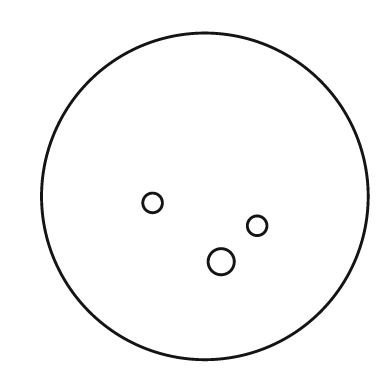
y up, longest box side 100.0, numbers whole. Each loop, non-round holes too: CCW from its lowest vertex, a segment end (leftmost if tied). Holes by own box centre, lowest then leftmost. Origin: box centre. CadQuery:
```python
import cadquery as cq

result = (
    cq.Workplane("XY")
    .moveTo(0.0, 0.0)
    .circle(50.0)
    .moveTo(5.0, -20.0)
    .circle(4.0)
    .moveTo(16.0, -9.0)
    .circle(3.0)
    .moveTo(-16.0, -2.0)
    .circle(3.0)
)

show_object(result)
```